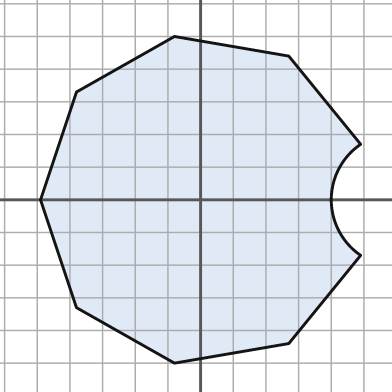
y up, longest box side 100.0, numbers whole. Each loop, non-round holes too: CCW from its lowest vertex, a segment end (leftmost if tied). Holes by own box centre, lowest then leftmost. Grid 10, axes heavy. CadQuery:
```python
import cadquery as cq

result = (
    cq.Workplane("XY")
    .moveTo(-8.0, -50.0)
    .lineTo(27.0, -44.0)
    .lineTo(49.0, -17.0)
    .threePointArc((40.0, 0.0), (49.0, 17.0))
    .lineTo(27.0, 44.0)
    .lineTo(-8.0, 50.0)
    .lineTo(-38.0, 33.0)
    .lineTo(-49.0, 0.0)
    .lineTo(-38.0, -33.0)
    .close()
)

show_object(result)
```